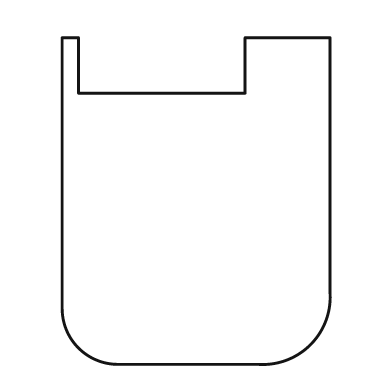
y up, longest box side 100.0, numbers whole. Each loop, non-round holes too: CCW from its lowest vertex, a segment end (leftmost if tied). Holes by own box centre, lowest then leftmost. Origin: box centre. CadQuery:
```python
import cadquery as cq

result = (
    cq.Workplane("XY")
    .moveTo(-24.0, -50.0)
    .lineTo(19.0, -50.0)
    .threePointArc((35.0, -44.0), (41.0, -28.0))
    .lineTo(41.0, 50.0)
    .lineTo(15.0, 50.0)
    .lineTo(15.0, 33.0)
    .lineTo(-36.0, 33.0)
    .lineTo(-36.0, 50.0)
    .lineTo(-41.0, 50.0)
    .lineTo(-41.0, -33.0)
    .threePointArc((-36.0, -45.0), (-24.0, -50.0))
    .close()
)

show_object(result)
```